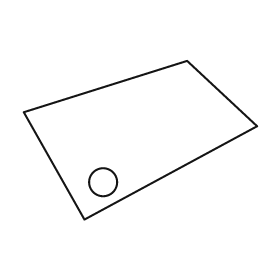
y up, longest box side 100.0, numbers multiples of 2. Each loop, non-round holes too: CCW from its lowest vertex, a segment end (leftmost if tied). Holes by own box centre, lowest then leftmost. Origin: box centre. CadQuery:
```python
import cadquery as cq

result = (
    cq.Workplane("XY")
    .moveTo(-24.0, -34.0)
    .lineTo(50.0, 6.0)
    .lineTo(20.0, 34.0)
    .lineTo(-50.0, 12.0)
    .close()
    .moveTo(-16.0, -18.0)
    .circle(6.0)
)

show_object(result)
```